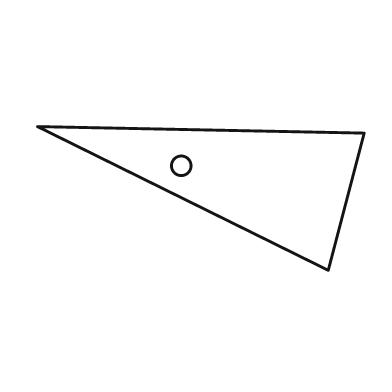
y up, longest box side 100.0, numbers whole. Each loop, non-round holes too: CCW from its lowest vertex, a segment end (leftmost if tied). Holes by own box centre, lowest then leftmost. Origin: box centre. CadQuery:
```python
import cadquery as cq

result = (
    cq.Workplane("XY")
    .moveTo(39.0, -22.0)
    .lineTo(50.0, 20.0)
    .lineTo(-50.0, 22.0)
    .close()
    .moveTo(-6.0, 10.0)
    .circle(3.0)
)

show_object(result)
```